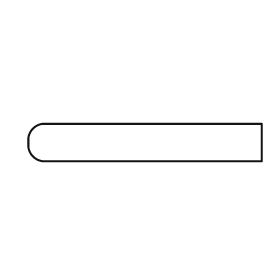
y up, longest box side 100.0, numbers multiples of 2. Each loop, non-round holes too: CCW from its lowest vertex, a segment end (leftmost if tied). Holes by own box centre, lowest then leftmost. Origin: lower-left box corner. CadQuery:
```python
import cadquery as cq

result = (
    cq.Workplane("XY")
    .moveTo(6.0, 0.0)
    .lineTo(100.0, 0.0)
    .lineTo(100.0, 16.0)
    .lineTo(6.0, 16.0)
    .threePointArc((2.0, 14.0), (0.0, 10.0))
    .lineTo(0.0, 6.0)
    .threePointArc((2.0, 2.0), (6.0, 0.0))
    .close()
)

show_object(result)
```